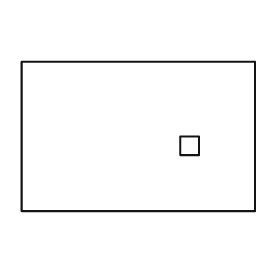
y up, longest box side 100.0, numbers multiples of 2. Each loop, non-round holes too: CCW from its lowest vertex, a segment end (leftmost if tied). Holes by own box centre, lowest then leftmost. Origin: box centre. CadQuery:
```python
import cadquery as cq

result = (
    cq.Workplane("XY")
    .moveTo(-50.0, -32.0)
    .lineTo(50.0, -32.0)
    .lineTo(50.0, 32.0)
    .lineTo(-50.0, 32.0)
    .close()
    .moveTo(18.0, -8.0)
    .lineTo(26.0, -8.0)
    .lineTo(26.0, 0.0)
    .lineTo(18.0, 0.0)
    .close()
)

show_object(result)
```